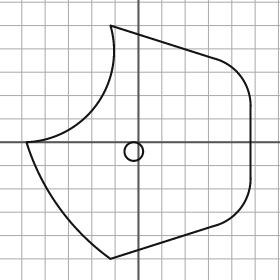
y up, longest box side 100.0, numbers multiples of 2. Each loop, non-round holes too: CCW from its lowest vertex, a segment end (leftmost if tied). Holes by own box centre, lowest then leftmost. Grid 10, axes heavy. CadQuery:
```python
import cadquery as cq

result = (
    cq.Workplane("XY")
    .moveTo(-12.0, -50.0)
    .lineTo(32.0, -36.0)
    .threePointArc((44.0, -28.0), (48.0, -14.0))
    .lineTo(48.0, 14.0)
    .threePointArc((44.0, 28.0), (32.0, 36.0))
    .lineTo(-12.0, 50.0)
    .threePointArc((-18.0, 16.0), (-48.0, 0.0))
    .threePointArc((-34.0, -28.0), (-12.0, -50.0))
    .close()
    .moveTo(-2.0, -4.0)
    .circle(4.0)
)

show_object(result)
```